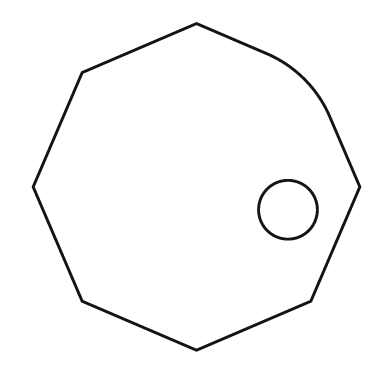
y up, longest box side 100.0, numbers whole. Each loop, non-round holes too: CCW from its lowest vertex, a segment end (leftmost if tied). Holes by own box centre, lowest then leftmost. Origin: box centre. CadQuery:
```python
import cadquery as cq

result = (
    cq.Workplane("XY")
    .moveTo(0.0, -50.0)
    .lineTo(35.0, -35.0)
    .lineTo(50.0, 0.0)
    .lineTo(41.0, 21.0)
    .threePointArc((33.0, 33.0), (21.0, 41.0))
    .lineTo(0.0, 50.0)
    .lineTo(-35.0, 35.0)
    .lineTo(-50.0, 0.0)
    .lineTo(-35.0, -35.0)
    .close()
    .moveTo(28.0, -7.0)
    .circle(9.0)
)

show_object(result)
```